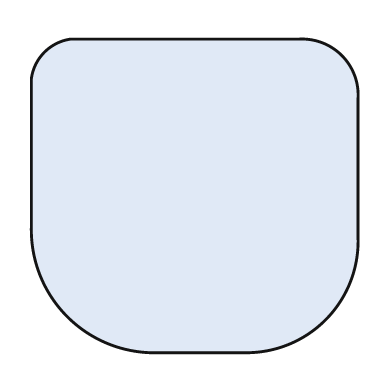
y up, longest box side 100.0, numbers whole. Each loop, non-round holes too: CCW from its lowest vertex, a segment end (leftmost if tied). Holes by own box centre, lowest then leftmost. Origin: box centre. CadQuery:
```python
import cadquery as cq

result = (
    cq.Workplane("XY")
    .moveTo(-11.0, -48.0)
    .lineTo(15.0, -48.0)
    .threePointArc((40.0, -38.0), (50.0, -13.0))
    .lineTo(50.0, 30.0)
    .threePointArc((45.0, 43.0), (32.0, 48.0))
    .lineTo(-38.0, 48.0)
    .threePointArc((-46.0, 44.0), (-50.0, 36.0))
    .lineTo(-50.0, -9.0)
    .threePointArc((-39.0, -37.0), (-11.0, -48.0))
    .close()
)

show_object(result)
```